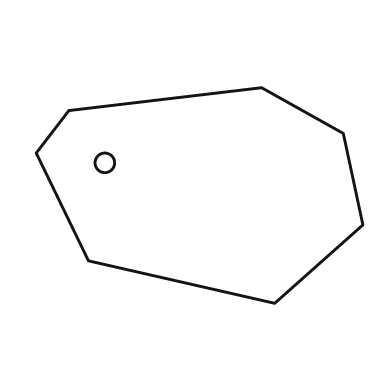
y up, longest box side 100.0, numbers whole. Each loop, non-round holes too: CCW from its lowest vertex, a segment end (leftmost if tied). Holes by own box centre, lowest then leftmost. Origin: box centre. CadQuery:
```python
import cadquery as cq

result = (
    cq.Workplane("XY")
    .moveTo(23.0, -33.0)
    .lineTo(50.0, -9.0)
    .lineTo(44.0, 19.0)
    .lineTo(19.0, 33.0)
    .lineTo(-40.0, 26.0)
    .lineTo(-50.0, 13.0)
    .lineTo(-34.0, -20.0)
    .close()
    .moveTo(-29.0, 10.0)
    .circle(3.0)
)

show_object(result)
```